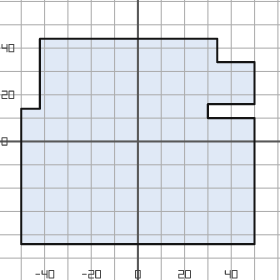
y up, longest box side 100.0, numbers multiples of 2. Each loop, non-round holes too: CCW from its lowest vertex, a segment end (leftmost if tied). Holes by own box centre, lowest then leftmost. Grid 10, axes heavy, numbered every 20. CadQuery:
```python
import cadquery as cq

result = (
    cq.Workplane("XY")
    .moveTo(-50.0, -44.0)
    .lineTo(50.0, -44.0)
    .lineTo(50.0, 10.0)
    .lineTo(30.0, 10.0)
    .lineTo(30.0, 16.0)
    .lineTo(50.0, 16.0)
    .lineTo(50.0, 34.0)
    .lineTo(34.0, 34.0)
    .lineTo(34.0, 44.0)
    .lineTo(-42.0, 44.0)
    .lineTo(-42.0, 14.0)
    .lineTo(-50.0, 14.0)
    .close()
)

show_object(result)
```